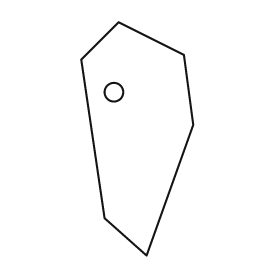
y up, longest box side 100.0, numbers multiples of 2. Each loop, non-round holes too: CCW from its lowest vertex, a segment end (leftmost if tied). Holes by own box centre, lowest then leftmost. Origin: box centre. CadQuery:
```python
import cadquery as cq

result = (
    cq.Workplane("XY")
    .moveTo(4.0, -50.0)
    .lineTo(24.0, 6.0)
    .lineTo(20.0, 36.0)
    .lineTo(-8.0, 50.0)
    .lineTo(-24.0, 34.0)
    .lineTo(-14.0, -34.0)
    .close()
    .moveTo(-10.0, 20.0)
    .circle(4.0)
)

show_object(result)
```